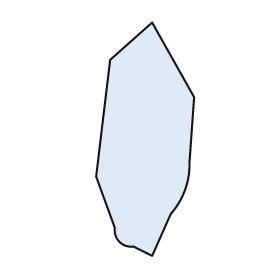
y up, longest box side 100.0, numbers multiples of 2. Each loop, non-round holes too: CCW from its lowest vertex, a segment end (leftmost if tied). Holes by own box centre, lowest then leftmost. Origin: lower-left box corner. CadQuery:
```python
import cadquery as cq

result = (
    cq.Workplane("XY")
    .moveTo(24.0, 0.0)
    .lineTo(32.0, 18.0)
    .threePointArc((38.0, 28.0), (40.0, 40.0))
    .lineTo(42.0, 68.0)
    .lineTo(24.0, 100.0)
    .lineTo(6.0, 84.0)
    .lineTo(0.0, 34.0)
    .lineTo(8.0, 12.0)
    .threePointArc((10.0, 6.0), (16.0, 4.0))
    .close()
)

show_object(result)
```